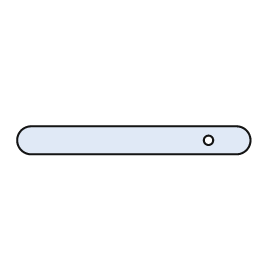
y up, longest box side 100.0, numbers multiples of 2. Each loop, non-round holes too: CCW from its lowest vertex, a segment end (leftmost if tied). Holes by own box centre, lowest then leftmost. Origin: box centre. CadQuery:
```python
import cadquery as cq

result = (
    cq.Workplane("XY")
    .moveTo(-44.0, -6.0)
    .lineTo(44.0, -6.0)
    .threePointArc((50.0, 0.0), (44.0, 6.0))
    .lineTo(-44.0, 6.0)
    .threePointArc((-50.0, 0.0), (-44.0, -6.0))
    .close()
    .moveTo(32.0, 0.0)
    .circle(2.0)
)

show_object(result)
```